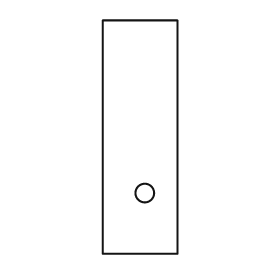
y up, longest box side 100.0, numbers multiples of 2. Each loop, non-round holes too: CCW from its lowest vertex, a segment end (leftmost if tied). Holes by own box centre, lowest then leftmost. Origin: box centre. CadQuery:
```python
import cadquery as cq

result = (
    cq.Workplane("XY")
    .moveTo(-16.0, -50.0)
    .lineTo(16.0, -50.0)
    .lineTo(16.0, 50.0)
    .lineTo(-16.0, 50.0)
    .close()
    .moveTo(2.0, -24.0)
    .circle(4.0)
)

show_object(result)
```